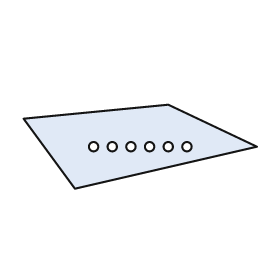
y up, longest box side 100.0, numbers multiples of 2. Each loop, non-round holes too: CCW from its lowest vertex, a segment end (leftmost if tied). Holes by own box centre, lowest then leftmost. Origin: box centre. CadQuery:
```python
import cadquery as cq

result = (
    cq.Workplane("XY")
    .moveTo(-28.0, -18.0)
    .lineTo(50.0, 0.0)
    .lineTo(12.0, 18.0)
    .lineTo(-50.0, 12.0)
    .close()
    .moveTo(-20.0, 0.0)
    .circle(2.0)
    .moveTo(-12.0, 0.0)
    .circle(2.0)
    .moveTo(-4.0, 0.0)
    .circle(2.0)
    .moveTo(4.0, 0.0)
    .circle(2.0)
    .moveTo(12.0, 0.0)
    .circle(2.0)
    .moveTo(20.0, 0.0)
    .circle(2.0)
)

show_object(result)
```